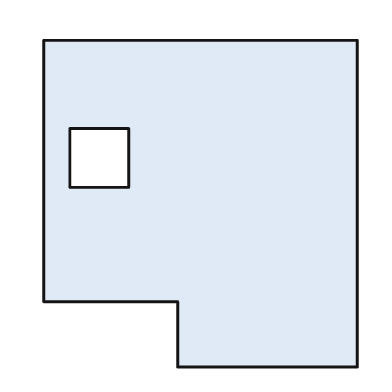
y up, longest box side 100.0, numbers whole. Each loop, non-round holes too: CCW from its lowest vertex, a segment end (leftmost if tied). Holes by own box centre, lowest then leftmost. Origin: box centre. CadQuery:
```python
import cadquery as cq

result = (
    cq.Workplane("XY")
    .moveTo(-7.0, -50.0)
    .lineTo(48.0, -50.0)
    .lineTo(48.0, 50.0)
    .lineTo(-48.0, 50.0)
    .lineTo(-48.0, -30.0)
    .lineTo(-7.0, -30.0)
    .close()
    .moveTo(-40.0, 5.0)
    .lineTo(-22.0, 5.0)
    .lineTo(-22.0, 23.0)
    .lineTo(-40.0, 23.0)
    .close()
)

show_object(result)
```